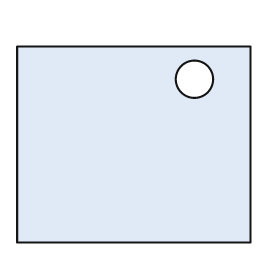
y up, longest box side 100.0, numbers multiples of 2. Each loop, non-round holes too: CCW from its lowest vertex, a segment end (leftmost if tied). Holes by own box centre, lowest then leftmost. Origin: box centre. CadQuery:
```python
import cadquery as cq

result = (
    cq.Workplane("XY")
    .moveTo(-50.0, -42.0)
    .lineTo(50.0, -42.0)
    .lineTo(50.0, 42.0)
    .lineTo(-50.0, 42.0)
    .close()
    .moveTo(26.0, 28.0)
    .circle(8.0)
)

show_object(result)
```